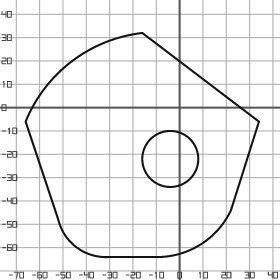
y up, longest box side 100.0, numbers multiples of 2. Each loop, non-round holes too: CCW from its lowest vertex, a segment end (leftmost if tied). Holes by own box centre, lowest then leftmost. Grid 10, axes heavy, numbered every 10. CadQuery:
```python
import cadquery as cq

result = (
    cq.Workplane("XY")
    .moveTo(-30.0, -64.0)
    .lineTo(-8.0, -64.0)
    .threePointArc((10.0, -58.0), (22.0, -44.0))
    .lineTo(34.0, -6.0)
    .lineTo(-16.0, 32.0)
    .threePointArc((-46.0, 20.0), (-66.0, -6.0))
    .lineTo(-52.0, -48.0)
    .threePointArc((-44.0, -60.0), (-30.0, -64.0))
    .close()
    .moveTo(-4.0, -22.0)
    .circle(12.0)
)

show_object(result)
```